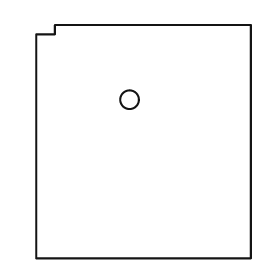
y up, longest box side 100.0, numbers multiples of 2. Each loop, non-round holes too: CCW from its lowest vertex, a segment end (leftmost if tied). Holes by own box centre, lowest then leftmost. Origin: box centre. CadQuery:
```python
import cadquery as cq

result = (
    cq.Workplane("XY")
    .moveTo(-46.0, -50.0)
    .lineTo(46.0, -50.0)
    .lineTo(46.0, 50.0)
    .lineTo(-38.0, 50.0)
    .lineTo(-38.0, 46.0)
    .lineTo(-46.0, 46.0)
    .close()
    .moveTo(-6.0, 18.0)
    .circle(4.0)
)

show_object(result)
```